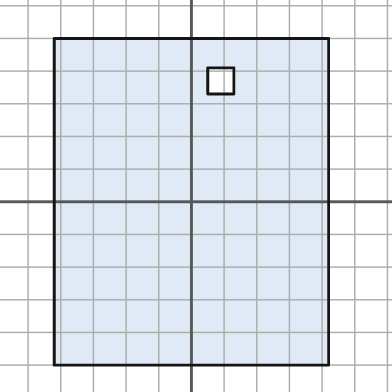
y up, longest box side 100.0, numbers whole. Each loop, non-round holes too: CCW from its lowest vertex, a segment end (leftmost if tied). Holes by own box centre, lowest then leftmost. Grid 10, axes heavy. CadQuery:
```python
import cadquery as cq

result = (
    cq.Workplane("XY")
    .moveTo(-42.0, -50.0)
    .lineTo(42.0, -50.0)
    .lineTo(42.0, 50.0)
    .lineTo(-42.0, 50.0)
    .close()
    .moveTo(5.0, 33.0)
    .lineTo(13.0, 33.0)
    .lineTo(13.0, 41.0)
    .lineTo(5.0, 41.0)
    .close()
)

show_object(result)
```